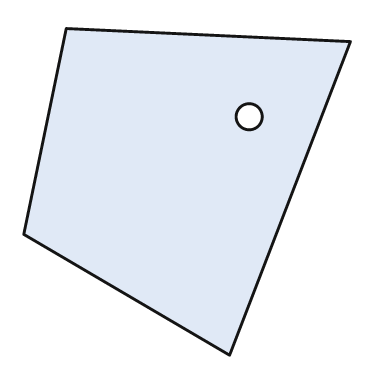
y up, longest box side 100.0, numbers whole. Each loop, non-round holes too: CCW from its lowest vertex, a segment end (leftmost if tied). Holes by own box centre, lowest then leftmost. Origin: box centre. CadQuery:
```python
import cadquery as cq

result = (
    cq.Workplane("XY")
    .moveTo(13.0, -50.0)
    .lineTo(50.0, 46.0)
    .lineTo(-37.0, 50.0)
    .lineTo(-50.0, -13.0)
    .close()
    .moveTo(19.0, 23.0)
    .circle(4.0)
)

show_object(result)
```